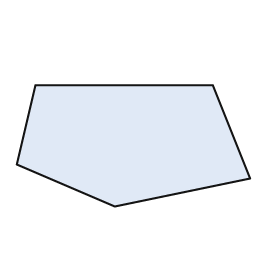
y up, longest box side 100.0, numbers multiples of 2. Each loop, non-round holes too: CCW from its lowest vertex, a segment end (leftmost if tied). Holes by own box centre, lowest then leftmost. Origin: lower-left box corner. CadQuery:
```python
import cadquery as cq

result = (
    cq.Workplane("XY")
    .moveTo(42.0, 0.0)
    .lineTo(100.0, 12.0)
    .lineTo(84.0, 52.0)
    .lineTo(8.0, 52.0)
    .lineTo(0.0, 18.0)
    .close()
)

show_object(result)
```